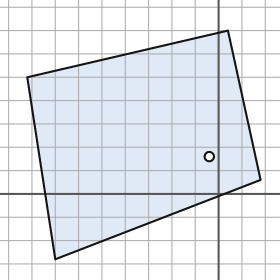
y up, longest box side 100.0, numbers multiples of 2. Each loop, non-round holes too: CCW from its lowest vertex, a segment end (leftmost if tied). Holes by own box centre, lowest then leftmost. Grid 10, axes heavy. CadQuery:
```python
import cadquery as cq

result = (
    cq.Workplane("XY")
    .moveTo(-70.0, -28.0)
    .lineTo(18.0, 6.0)
    .lineTo(4.0, 70.0)
    .lineTo(-82.0, 50.0)
    .close()
    .moveTo(-4.0, 16.0)
    .circle(2.0)
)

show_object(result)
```